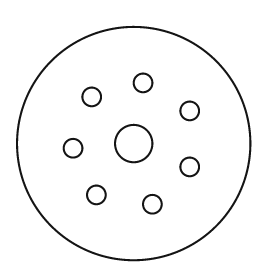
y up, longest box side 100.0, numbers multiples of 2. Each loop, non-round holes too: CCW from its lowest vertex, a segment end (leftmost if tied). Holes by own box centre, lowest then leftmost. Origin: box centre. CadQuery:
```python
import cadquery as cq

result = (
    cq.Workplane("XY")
    .moveTo(0.0, 0.0)
    .circle(50.0)
    .moveTo(8.0, -26.0)
    .circle(4.0)
    .moveTo(-16.0, -22.0)
    .circle(4.0)
    .moveTo(24.0, -10.0)
    .circle(4.0)
    .moveTo(-26.0, -2.0)
    .circle(4.0)
    .moveTo(0.0, 0.0)
    .circle(8.0)
    .moveTo(24.0, 14.0)
    .circle(4.0)
    .moveTo(-18.0, 20.0)
    .circle(4.0)
    .moveTo(4.0, 26.0)
    .circle(4.0)
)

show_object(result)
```